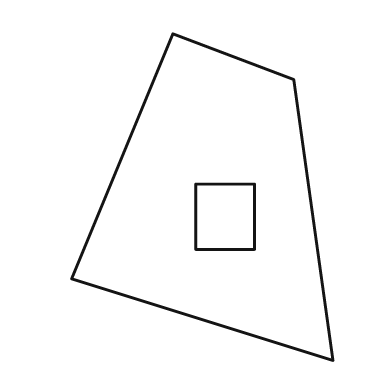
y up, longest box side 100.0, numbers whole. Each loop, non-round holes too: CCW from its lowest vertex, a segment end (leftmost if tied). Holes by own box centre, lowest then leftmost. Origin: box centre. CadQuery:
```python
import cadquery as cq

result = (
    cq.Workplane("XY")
    .moveTo(40.0, -50.0)
    .lineTo(28.0, 36.0)
    .lineTo(-9.0, 50.0)
    .lineTo(-40.0, -25.0)
    .close()
    .moveTo(-2.0, -16.0)
    .lineTo(16.0, -16.0)
    .lineTo(16.0, 4.0)
    .lineTo(-2.0, 4.0)
    .close()
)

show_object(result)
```